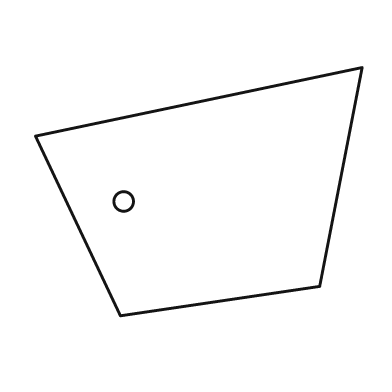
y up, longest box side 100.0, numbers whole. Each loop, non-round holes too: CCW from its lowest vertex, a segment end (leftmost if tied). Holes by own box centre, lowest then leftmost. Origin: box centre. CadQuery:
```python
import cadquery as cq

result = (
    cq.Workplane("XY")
    .moveTo(-24.0, -38.0)
    .lineTo(37.0, -29.0)
    .lineTo(50.0, 38.0)
    .lineTo(-50.0, 17.0)
    .close()
    .moveTo(-23.0, -3.0)
    .circle(3.0)
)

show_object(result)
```